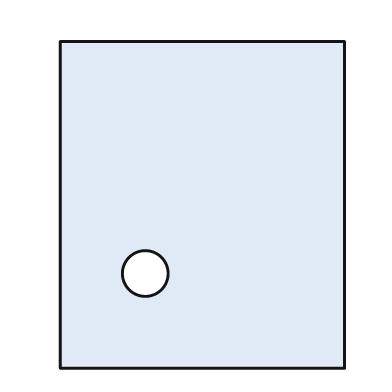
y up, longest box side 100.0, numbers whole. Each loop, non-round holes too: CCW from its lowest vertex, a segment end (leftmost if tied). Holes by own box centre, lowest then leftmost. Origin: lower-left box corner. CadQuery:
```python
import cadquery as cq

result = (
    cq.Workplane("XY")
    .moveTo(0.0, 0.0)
    .lineTo(87.0, 0.0)
    .lineTo(87.0, 100.0)
    .lineTo(0.0, 100.0)
    .close()
    .moveTo(26.0, 29.0)
    .circle(7.0)
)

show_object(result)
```